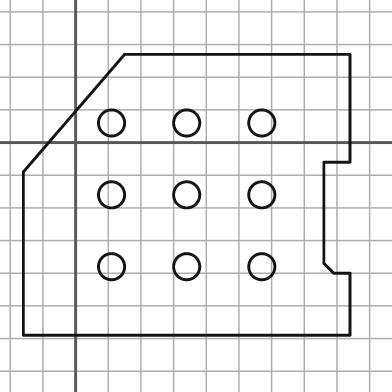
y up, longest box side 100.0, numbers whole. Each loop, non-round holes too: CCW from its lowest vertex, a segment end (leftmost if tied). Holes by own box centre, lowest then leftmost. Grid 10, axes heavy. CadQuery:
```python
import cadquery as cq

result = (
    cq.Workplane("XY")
    .moveTo(-16.0, -59.0)
    .lineTo(84.0, -59.0)
    .lineTo(84.0, -40.0)
    .lineTo(79.0, -40.0)
    .lineTo(76.0, -37.0)
    .lineTo(76.0, -6.0)
    .lineTo(84.0, -6.0)
    .lineTo(84.0, 27.0)
    .lineTo(15.0, 27.0)
    .lineTo(-16.0, -9.0)
    .close()
    .moveTo(11.0, -38.0)
    .circle(4.0)
    .moveTo(34.0, -38.0)
    .circle(4.0)
    .moveTo(57.0, -38.0)
    .circle(4.0)
    .moveTo(11.0, -16.0)
    .circle(4.0)
    .moveTo(34.0, -16.0)
    .circle(4.0)
    .moveTo(57.0, -16.0)
    .circle(4.0)
    .moveTo(11.0, 6.0)
    .circle(4.0)
    .moveTo(34.0, 6.0)
    .circle(4.0)
    .moveTo(57.0, 6.0)
    .circle(4.0)
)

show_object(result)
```